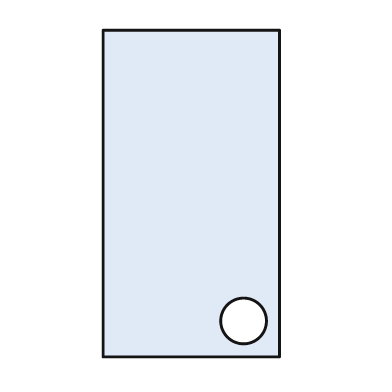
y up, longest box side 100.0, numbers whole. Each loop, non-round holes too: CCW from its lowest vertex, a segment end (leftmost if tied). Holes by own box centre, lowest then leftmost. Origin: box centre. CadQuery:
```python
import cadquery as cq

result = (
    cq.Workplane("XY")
    .moveTo(-27.0, -50.0)
    .lineTo(27.0, -50.0)
    .lineTo(27.0, 50.0)
    .lineTo(-27.0, 50.0)
    .close()
    .moveTo(16.0, -39.0)
    .circle(7.0)
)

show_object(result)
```